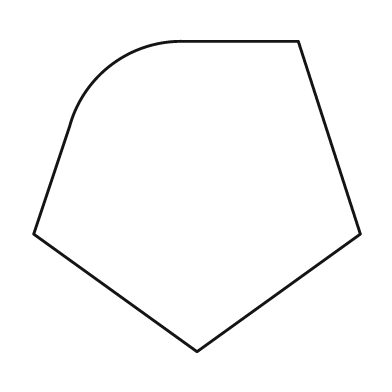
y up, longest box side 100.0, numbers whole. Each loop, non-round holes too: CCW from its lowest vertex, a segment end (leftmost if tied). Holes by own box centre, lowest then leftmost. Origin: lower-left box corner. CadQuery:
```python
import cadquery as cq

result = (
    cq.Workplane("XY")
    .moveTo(50.0, 0.0)
    .lineTo(100.0, 36.0)
    .lineTo(81.0, 95.0)
    .lineTo(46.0, 95.0)
    .threePointArc((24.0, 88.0), (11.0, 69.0))
    .lineTo(0.0, 36.0)
    .close()
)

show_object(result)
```